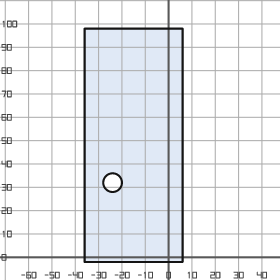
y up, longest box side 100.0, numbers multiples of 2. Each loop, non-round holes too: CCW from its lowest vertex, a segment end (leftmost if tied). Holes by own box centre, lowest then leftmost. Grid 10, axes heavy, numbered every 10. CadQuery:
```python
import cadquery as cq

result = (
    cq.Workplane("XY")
    .moveTo(-36.0, -2.0)
    .lineTo(6.0, -2.0)
    .lineTo(6.0, 98.0)
    .lineTo(-36.0, 98.0)
    .close()
    .moveTo(-24.0, 32.0)
    .circle(4.0)
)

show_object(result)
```